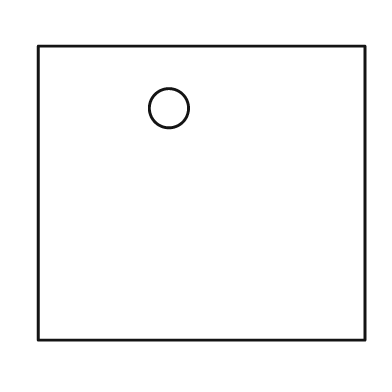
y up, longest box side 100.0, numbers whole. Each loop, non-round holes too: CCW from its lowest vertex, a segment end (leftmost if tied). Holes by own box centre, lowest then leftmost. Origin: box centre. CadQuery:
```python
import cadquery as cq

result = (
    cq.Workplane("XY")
    .moveTo(-50.0, -45.0)
    .lineTo(50.0, -45.0)
    .lineTo(50.0, 45.0)
    .lineTo(-50.0, 45.0)
    .close()
    .moveTo(-10.0, 26.0)
    .circle(6.0)
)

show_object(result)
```